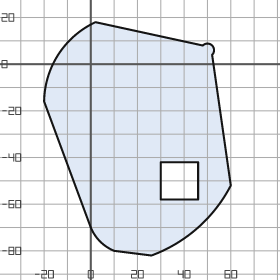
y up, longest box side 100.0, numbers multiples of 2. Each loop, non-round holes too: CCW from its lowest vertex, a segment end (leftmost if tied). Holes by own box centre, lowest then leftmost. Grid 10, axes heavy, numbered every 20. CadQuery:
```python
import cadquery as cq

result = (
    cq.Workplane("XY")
    .moveTo(26.0, -82.0)
    .threePointArc((46.0, -70.0), (60.0, -52.0))
    .lineTo(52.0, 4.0)
    .threePointArc((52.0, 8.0), (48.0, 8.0))
    .lineTo(2.0, 18.0)
    .threePointArc((-14.0, 4.0), (-20.0, -16.0))
    .lineTo(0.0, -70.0)
    .threePointArc((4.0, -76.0), (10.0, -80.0))
    .close()
    .moveTo(30.0, -58.0)
    .lineTo(46.0, -58.0)
    .lineTo(46.0, -42.0)
    .lineTo(30.0, -42.0)
    .close()
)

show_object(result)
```